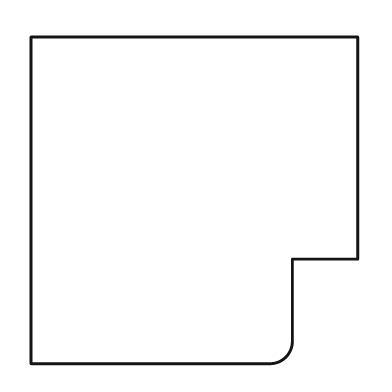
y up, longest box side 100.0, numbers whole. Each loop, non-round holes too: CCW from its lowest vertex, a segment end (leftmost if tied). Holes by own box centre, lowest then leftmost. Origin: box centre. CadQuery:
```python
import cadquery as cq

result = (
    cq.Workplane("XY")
    .moveTo(-50.0, -50.0)
    .lineTo(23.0, -50.0)
    .threePointArc((28.0, -48.0), (30.0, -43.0))
    .lineTo(30.0, -18.0)
    .lineTo(50.0, -18.0)
    .lineTo(50.0, 50.0)
    .lineTo(-50.0, 50.0)
    .close()
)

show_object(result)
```